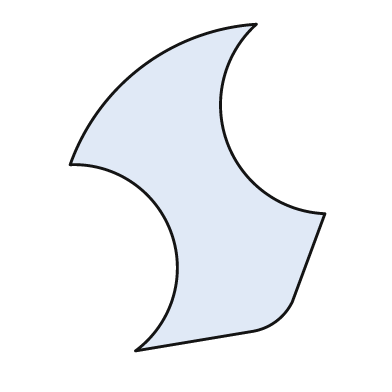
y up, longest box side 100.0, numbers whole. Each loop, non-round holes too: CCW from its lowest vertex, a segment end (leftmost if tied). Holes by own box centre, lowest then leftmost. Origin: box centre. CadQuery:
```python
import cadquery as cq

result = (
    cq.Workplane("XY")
    .moveTo(-19.0, -50.0)
    .lineTo(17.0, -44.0)
    .threePointArc((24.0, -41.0), (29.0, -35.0))
    .lineTo(39.0, -8.0)
    .threePointArc((9.0, 14.0), (18.0, 50.0))
    .threePointArc((-17.0, 37.0), (-39.0, 7.0))
    .threePointArc((-8.0, -14.0), (-19.0, -50.0))
    .close()
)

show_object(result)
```